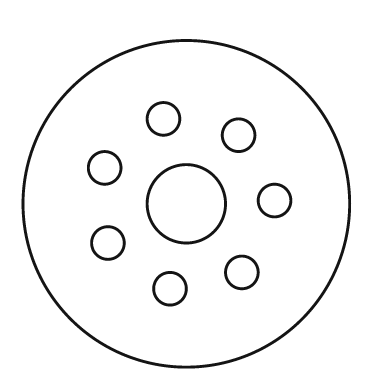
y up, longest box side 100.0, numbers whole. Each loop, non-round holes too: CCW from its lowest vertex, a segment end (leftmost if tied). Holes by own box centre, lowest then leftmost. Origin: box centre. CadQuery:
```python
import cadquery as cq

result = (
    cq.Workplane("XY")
    .moveTo(0.0, 0.0)
    .circle(50.0)
    .moveTo(-5.0, -26.0)
    .circle(5.0)
    .moveTo(17.0, -21.0)
    .circle(5.0)
    .moveTo(-24.0, -12.0)
    .circle(5.0)
    .moveTo(0.0, 0.0)
    .circle(12.0)
    .moveTo(27.0, 1.0)
    .circle(5.0)
    .moveTo(-25.0, 11.0)
    .circle(5.0)
    .moveTo(16.0, 21.0)
    .circle(5.0)
    .moveTo(-7.0, 26.0)
    .circle(5.0)
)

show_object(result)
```